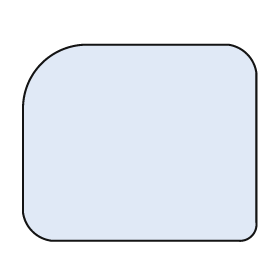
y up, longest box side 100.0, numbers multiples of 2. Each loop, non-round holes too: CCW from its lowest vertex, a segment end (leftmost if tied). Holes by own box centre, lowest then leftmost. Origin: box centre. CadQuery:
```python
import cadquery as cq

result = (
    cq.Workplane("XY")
    .moveTo(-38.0, -42.0)
    .lineTo(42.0, -42.0)
    .threePointArc((48.0, -40.0), (50.0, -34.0))
    .lineTo(50.0, 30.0)
    .threePointArc((46.0, 38.0), (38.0, 42.0))
    .lineTo(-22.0, 42.0)
    .threePointArc((-42.0, 34.0), (-50.0, 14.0))
    .lineTo(-50.0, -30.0)
    .threePointArc((-46.0, -38.0), (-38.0, -42.0))
    .close()
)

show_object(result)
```